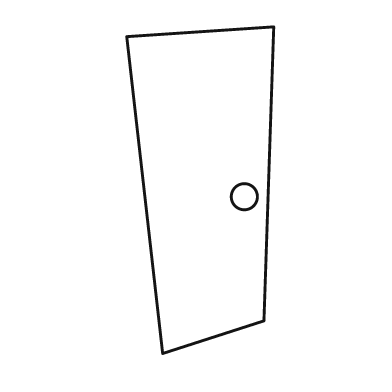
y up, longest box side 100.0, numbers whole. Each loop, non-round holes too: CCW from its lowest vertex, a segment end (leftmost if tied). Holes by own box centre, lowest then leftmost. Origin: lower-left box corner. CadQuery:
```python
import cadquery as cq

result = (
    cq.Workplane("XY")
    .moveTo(11.0, 0.0)
    .lineTo(42.0, 10.0)
    .lineTo(45.0, 100.0)
    .lineTo(0.0, 97.0)
    .close()
    .moveTo(36.0, 48.0)
    .circle(4.0)
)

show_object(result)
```